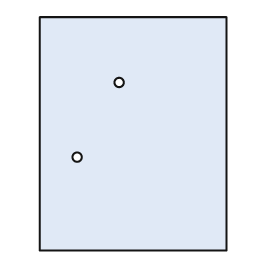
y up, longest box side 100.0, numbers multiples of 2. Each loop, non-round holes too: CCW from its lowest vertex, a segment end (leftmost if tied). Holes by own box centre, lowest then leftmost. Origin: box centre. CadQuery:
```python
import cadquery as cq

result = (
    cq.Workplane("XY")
    .moveTo(-40.0, -50.0)
    .lineTo(40.0, -50.0)
    .lineTo(40.0, 50.0)
    .lineTo(-40.0, 50.0)
    .close()
    .moveTo(-24.0, -10.0)
    .circle(2.0)
    .moveTo(-6.0, 22.0)
    .circle(2.0)
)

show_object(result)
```